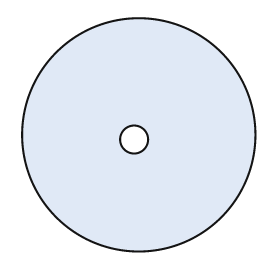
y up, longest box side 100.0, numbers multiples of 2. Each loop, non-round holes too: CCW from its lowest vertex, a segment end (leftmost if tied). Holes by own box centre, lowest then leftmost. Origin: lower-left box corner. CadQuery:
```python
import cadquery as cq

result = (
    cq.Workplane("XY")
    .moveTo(50.0, 50.0)
    .circle(50.0)
    .moveTo(48.0, 48.0)
    .circle(6.0)
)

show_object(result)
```